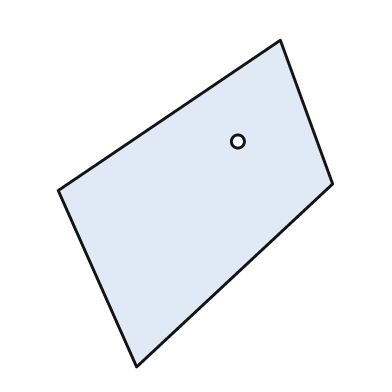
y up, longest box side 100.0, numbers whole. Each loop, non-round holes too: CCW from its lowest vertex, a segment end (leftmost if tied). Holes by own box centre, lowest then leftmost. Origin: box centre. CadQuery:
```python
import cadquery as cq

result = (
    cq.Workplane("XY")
    .moveTo(-18.0, -50.0)
    .lineTo(42.0, 6.0)
    .lineTo(26.0, 50.0)
    .lineTo(-42.0, 4.0)
    .close()
    .moveTo(13.0, 19.0)
    .circle(2.0)
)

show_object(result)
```